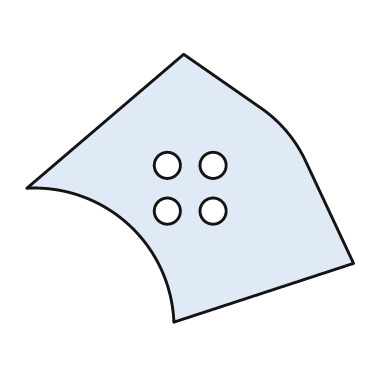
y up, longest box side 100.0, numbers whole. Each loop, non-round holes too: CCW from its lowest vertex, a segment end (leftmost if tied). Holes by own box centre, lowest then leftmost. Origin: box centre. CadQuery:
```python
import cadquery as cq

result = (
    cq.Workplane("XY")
    .moveTo(-5.0, -41.0)
    .lineTo(50.0, -23.0)
    .lineTo(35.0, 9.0)
    .threePointArc((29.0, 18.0), (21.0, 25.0))
    .lineTo(-2.0, 41.0)
    .lineTo(-50.0, 0.0)
    .threePointArc((-19.0, -11.0), (-5.0, -41.0))
    .close()
    .moveTo(-7.0, -7.0)
    .circle(4.0)
    .moveTo(7.0, -7.0)
    .circle(4.0)
    .moveTo(-7.0, 7.0)
    .circle(4.0)
    .moveTo(7.0, 7.0)
    .circle(4.0)
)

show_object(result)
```